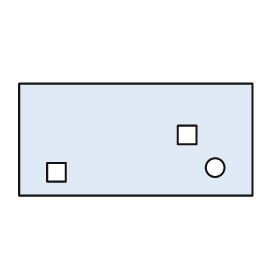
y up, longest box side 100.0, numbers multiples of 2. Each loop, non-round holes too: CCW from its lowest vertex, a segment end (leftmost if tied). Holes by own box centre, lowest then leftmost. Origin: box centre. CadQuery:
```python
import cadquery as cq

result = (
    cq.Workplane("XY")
    .moveTo(-50.0, -24.0)
    .lineTo(50.0, -24.0)
    .lineTo(50.0, 24.0)
    .lineTo(-50.0, 24.0)
    .close()
    .moveTo(-38.0, -18.0)
    .lineTo(-30.0, -18.0)
    .lineTo(-30.0, -10.0)
    .lineTo(-38.0, -10.0)
    .close()
    .moveTo(34.0, -12.0)
    .circle(4.0)
    .moveTo(18.0, -2.0)
    .lineTo(26.0, -2.0)
    .lineTo(26.0, 6.0)
    .lineTo(18.0, 6.0)
    .close()
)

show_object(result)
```